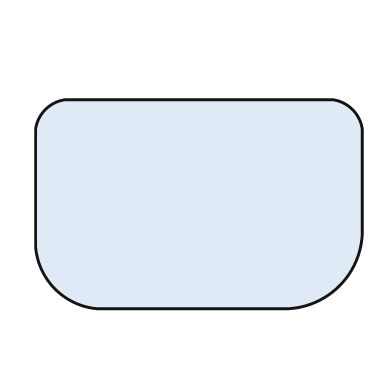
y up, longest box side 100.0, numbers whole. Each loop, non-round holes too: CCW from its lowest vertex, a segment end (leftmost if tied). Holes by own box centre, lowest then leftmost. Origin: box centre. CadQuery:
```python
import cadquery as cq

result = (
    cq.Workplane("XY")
    .moveTo(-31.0, -32.0)
    .lineTo(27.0, -32.0)
    .threePointArc((43.0, -25.0), (50.0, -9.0))
    .lineTo(50.0, 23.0)
    .threePointArc((47.0, 29.0), (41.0, 32.0))
    .lineTo(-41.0, 32.0)
    .threePointArc((-47.0, 29.0), (-50.0, 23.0))
    .lineTo(-50.0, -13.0)
    .threePointArc((-44.0, -26.0), (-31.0, -32.0))
    .close()
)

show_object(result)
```